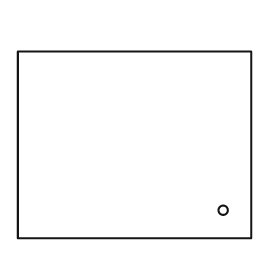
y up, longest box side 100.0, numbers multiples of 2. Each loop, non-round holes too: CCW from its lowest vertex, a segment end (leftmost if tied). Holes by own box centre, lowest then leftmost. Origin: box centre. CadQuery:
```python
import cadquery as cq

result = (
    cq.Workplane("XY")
    .moveTo(-50.0, -40.0)
    .lineTo(50.0, -40.0)
    .lineTo(50.0, 40.0)
    .lineTo(-50.0, 40.0)
    .close()
    .moveTo(38.0, -28.0)
    .circle(2.0)
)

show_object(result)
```